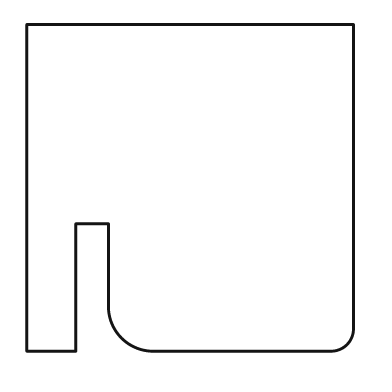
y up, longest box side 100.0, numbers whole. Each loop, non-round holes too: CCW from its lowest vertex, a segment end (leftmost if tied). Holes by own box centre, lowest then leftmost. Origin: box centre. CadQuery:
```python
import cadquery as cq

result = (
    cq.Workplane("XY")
    .moveTo(-50.0, -50.0)
    .lineTo(-35.0, -50.0)
    .lineTo(-35.0, -11.0)
    .lineTo(-25.0, -11.0)
    .lineTo(-25.0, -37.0)
    .threePointArc((-21.0, -46.0), (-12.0, -50.0))
    .lineTo(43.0, -50.0)
    .threePointArc((48.0, -48.0), (50.0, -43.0))
    .lineTo(50.0, 50.0)
    .lineTo(-50.0, 50.0)
    .close()
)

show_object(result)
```